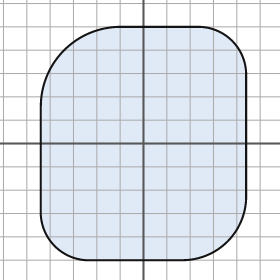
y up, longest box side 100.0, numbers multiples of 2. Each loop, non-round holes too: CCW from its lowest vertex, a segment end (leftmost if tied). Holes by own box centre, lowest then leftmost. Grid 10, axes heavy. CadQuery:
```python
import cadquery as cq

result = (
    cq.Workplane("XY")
    .moveTo(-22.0, -50.0)
    .lineTo(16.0, -50.0)
    .threePointArc((36.0, -42.0), (44.0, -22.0))
    .lineTo(44.0, 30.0)
    .threePointArc((38.0, 44.0), (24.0, 50.0))
    .lineTo(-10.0, 50.0)
    .threePointArc((-34.0, 40.0), (-44.0, 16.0))
    .lineTo(-44.0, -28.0)
    .threePointArc((-38.0, -44.0), (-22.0, -50.0))
    .close()
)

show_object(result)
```